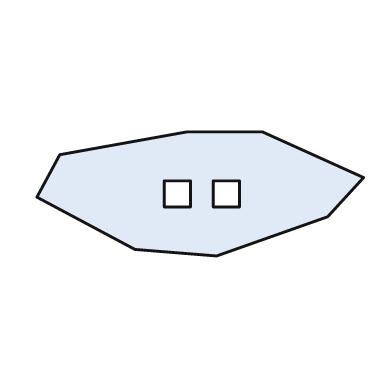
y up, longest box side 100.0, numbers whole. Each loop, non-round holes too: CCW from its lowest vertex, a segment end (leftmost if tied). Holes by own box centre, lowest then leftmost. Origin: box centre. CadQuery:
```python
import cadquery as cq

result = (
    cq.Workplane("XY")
    .moveTo(5.0, -19.0)
    .lineTo(39.0, -7.0)
    .lineTo(50.0, 5.0)
    .lineTo(19.0, 19.0)
    .lineTo(-4.0, 19.0)
    .lineTo(-43.0, 12.0)
    .lineTo(-50.0, -1.0)
    .lineTo(-20.0, -17.0)
    .close()
    .moveTo(-11.0, -4.0)
    .lineTo(-3.0, -4.0)
    .lineTo(-3.0, 4.0)
    .lineTo(-11.0, 4.0)
    .close()
    .moveTo(4.0, -4.0)
    .lineTo(12.0, -4.0)
    .lineTo(12.0, 4.0)
    .lineTo(4.0, 4.0)
    .close()
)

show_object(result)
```